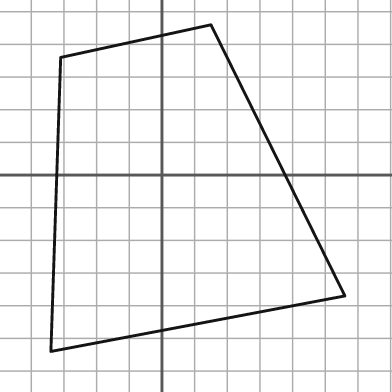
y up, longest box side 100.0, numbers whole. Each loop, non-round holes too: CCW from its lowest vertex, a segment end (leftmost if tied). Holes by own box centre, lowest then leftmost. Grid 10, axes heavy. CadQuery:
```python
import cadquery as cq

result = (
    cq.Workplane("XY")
    .moveTo(-34.0, -54.0)
    .lineTo(56.0, -37.0)
    .lineTo(15.0, 46.0)
    .lineTo(-31.0, 36.0)
    .close()
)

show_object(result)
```